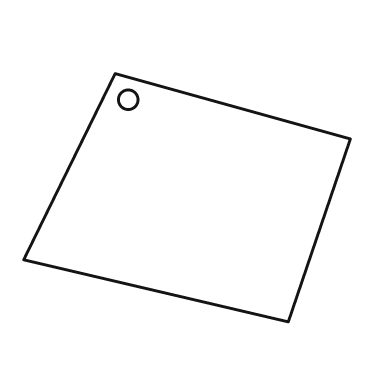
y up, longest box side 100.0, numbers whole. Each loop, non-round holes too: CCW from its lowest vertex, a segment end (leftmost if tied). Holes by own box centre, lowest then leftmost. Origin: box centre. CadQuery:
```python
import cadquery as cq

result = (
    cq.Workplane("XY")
    .moveTo(31.0, -38.0)
    .lineTo(50.0, 18.0)
    .lineTo(-22.0, 38.0)
    .lineTo(-50.0, -19.0)
    .close()
    .moveTo(-18.0, 30.0)
    .circle(3.0)
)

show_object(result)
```